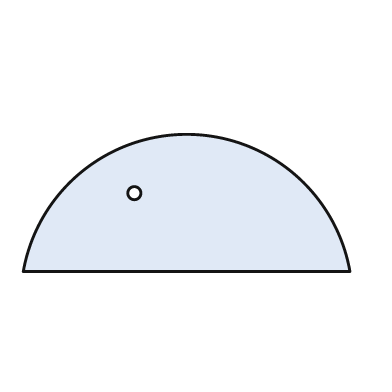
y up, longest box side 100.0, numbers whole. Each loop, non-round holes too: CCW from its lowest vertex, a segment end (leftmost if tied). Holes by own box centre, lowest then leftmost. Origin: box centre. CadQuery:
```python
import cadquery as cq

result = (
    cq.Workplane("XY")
    .moveTo(-50.0, -21.0)
    .lineTo(50.0, -21.0)
    .threePointArc((0.0, 21.0), (-50.0, -21.0))
    .close()
    .moveTo(-16.0, 3.0)
    .circle(2.0)
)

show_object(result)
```